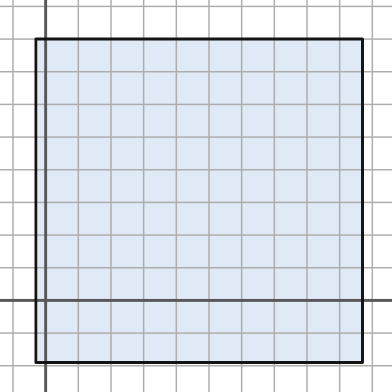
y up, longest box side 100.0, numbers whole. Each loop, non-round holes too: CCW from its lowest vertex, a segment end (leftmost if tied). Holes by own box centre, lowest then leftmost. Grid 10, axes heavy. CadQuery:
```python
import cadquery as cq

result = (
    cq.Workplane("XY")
    .moveTo(-3.0, -19.0)
    .lineTo(97.0, -19.0)
    .lineTo(97.0, 80.0)
    .lineTo(-3.0, 80.0)
    .close()
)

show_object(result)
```